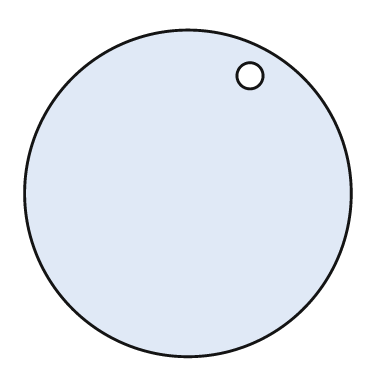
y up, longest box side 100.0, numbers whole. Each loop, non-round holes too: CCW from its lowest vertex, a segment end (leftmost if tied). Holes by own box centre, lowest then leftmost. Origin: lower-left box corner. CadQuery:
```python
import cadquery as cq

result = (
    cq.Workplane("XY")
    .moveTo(50.0, 50.0)
    .circle(50.0)
    .moveTo(69.0, 86.0)
    .circle(4.0)
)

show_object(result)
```